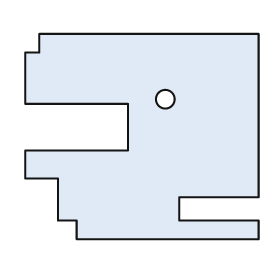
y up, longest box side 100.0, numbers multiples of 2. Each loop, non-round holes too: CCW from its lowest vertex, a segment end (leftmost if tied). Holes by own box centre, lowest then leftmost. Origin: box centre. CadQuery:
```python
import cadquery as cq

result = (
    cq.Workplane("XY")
    .moveTo(-28.0, -44.0)
    .lineTo(50.0, -44.0)
    .lineTo(50.0, -36.0)
    .lineTo(16.0, -36.0)
    .lineTo(16.0, -26.0)
    .lineTo(50.0, -26.0)
    .lineTo(50.0, 44.0)
    .lineTo(-44.0, 44.0)
    .lineTo(-44.0, 36.0)
    .lineTo(-50.0, 36.0)
    .lineTo(-50.0, 14.0)
    .lineTo(-6.0, 14.0)
    .lineTo(-6.0, -6.0)
    .lineTo(-50.0, -6.0)
    .lineTo(-50.0, -18.0)
    .lineTo(-36.0, -18.0)
    .lineTo(-36.0, -36.0)
    .lineTo(-28.0, -36.0)
    .close()
    .moveTo(10.0, 16.0)
    .circle(4.0)
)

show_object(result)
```